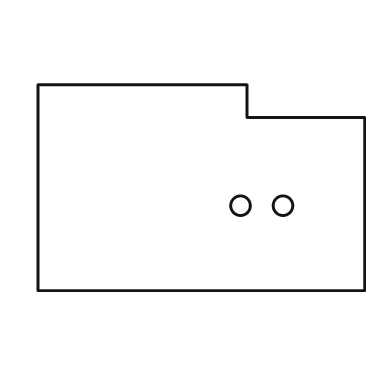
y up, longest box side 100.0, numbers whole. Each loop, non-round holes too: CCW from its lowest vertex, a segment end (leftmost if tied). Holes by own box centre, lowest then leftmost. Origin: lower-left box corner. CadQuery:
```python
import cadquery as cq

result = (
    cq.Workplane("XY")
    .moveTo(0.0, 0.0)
    .lineTo(100.0, 0.0)
    .lineTo(100.0, 53.0)
    .lineTo(64.0, 53.0)
    .lineTo(64.0, 63.0)
    .lineTo(0.0, 63.0)
    .close()
    .moveTo(62.0, 26.0)
    .circle(3.0)
    .moveTo(75.0, 26.0)
    .circle(3.0)
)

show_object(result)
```